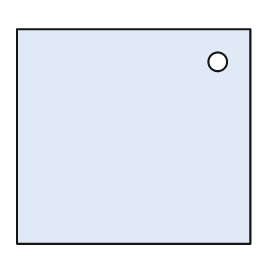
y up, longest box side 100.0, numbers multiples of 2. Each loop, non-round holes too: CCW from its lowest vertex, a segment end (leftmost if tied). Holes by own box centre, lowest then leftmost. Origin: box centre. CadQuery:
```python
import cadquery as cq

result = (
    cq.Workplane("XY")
    .moveTo(-50.0, -46.0)
    .lineTo(50.0, -46.0)
    .lineTo(50.0, 46.0)
    .lineTo(-50.0, 46.0)
    .close()
    .moveTo(36.0, 32.0)
    .circle(4.0)
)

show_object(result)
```